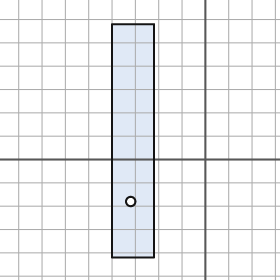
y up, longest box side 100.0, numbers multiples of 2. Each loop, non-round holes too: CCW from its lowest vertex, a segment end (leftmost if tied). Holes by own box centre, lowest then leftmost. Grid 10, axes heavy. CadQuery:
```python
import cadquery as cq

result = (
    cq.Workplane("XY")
    .moveTo(-40.0, -42.0)
    .lineTo(-22.0, -42.0)
    .lineTo(-22.0, 58.0)
    .lineTo(-40.0, 58.0)
    .close()
    .moveTo(-32.0, -18.0)
    .circle(2.0)
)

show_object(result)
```